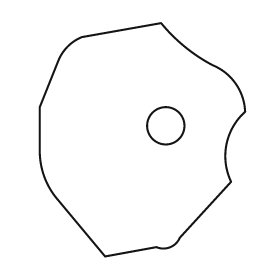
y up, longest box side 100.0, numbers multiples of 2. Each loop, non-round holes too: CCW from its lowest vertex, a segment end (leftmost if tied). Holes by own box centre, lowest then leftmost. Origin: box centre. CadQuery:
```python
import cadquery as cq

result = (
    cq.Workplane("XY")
    .moveTo(-16.0, -50.0)
    .lineTo(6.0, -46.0)
    .threePointArc((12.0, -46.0), (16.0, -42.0))
    .lineTo(38.0, -18.0)
    .threePointArc((36.0, -2.0), (44.0, 12.0))
    .threePointArc((40.0, 24.0), (30.0, 32.0))
    .threePointArc((18.0, 40.0), (8.0, 50.0))
    .lineTo(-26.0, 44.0)
    .threePointArc((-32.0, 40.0), (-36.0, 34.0))
    .lineTo(-44.0, 14.0)
    .lineTo(-44.0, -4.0)
    .threePointArc((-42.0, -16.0), (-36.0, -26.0))
    .close()
    .moveTo(10.0, 6.0)
    .circle(8.0)
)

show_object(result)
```